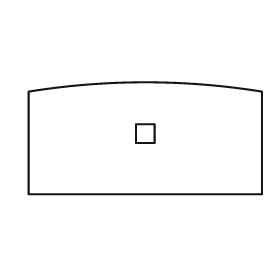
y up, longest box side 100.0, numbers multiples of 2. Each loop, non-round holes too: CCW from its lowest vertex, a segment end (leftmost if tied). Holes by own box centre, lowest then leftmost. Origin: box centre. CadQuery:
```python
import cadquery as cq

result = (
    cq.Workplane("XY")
    .moveTo(-50.0, -24.0)
    .lineTo(50.0, -24.0)
    .lineTo(50.0, 20.0)
    .threePointArc((0.0, 24.0), (-50.0, 20.0))
    .close()
    .moveTo(-4.0, -2.0)
    .lineTo(4.0, -2.0)
    .lineTo(4.0, 6.0)
    .lineTo(-4.0, 6.0)
    .close()
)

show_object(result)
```